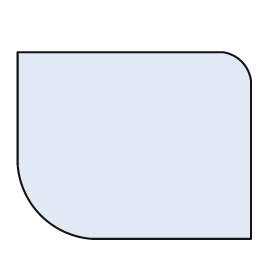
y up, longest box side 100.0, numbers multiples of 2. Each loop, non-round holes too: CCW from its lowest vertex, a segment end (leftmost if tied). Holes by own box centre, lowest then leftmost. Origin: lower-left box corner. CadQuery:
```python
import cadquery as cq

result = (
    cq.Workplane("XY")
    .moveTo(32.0, 0.0)
    .lineTo(100.0, 0.0)
    .lineTo(100.0, 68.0)
    .threePointArc((96.0, 76.0), (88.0, 80.0))
    .lineTo(0.0, 80.0)
    .lineTo(0.0, 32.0)
    .threePointArc((10.0, 10.0), (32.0, 0.0))
    .close()
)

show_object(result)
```